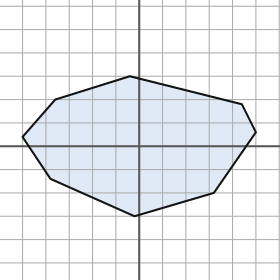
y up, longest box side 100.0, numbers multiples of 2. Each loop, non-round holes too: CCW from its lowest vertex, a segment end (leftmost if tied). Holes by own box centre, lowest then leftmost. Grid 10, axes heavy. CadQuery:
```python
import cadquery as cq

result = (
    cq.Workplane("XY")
    .moveTo(-2.0, -30.0)
    .lineTo(32.0, -20.0)
    .lineTo(50.0, 6.0)
    .lineTo(44.0, 18.0)
    .lineTo(-4.0, 30.0)
    .lineTo(-36.0, 20.0)
    .lineTo(-50.0, 4.0)
    .lineTo(-38.0, -14.0)
    .close()
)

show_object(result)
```